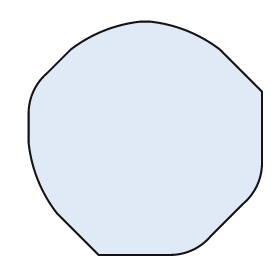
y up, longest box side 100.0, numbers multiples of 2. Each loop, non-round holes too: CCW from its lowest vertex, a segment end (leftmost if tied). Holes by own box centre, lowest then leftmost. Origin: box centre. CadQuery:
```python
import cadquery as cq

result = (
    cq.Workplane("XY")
    .moveTo(-20.0, -50.0)
    .lineTo(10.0, -50.0)
    .threePointArc((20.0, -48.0), (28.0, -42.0))
    .lineTo(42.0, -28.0)
    .threePointArc((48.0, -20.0), (50.0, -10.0))
    .lineTo(50.0, 20.0)
    .lineTo(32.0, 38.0)
    .threePointArc((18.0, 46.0), (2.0, 50.0))
    .lineTo(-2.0, 50.0)
    .threePointArc((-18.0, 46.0), (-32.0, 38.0))
    .lineTo(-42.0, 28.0)
    .threePointArc((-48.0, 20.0), (-50.0, 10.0))
    .lineTo(-50.0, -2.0)
    .threePointArc((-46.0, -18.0), (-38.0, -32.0))
    .close()
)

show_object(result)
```